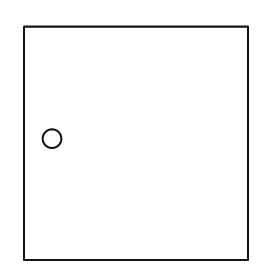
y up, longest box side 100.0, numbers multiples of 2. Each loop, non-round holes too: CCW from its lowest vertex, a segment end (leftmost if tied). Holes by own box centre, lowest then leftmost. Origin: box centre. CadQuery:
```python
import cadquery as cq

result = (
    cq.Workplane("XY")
    .moveTo(-48.0, -50.0)
    .lineTo(48.0, -50.0)
    .lineTo(48.0, 50.0)
    .lineTo(-48.0, 50.0)
    .close()
    .moveTo(-36.0, 2.0)
    .circle(4.0)
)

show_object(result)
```